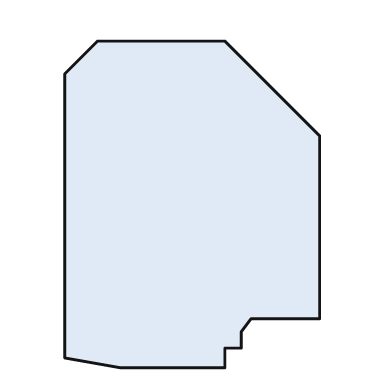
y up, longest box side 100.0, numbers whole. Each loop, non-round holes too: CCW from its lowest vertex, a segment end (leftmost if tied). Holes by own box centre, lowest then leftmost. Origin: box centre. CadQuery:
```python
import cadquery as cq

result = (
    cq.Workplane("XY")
    .moveTo(-22.0, -50.0)
    .lineTo(10.0, -50.0)
    .lineTo(10.0, -44.0)
    .lineTo(15.0, -44.0)
    .lineTo(15.0, -39.0)
    .lineTo(18.0, -35.0)
    .lineTo(39.0, -35.0)
    .lineTo(39.0, 21.0)
    .lineTo(10.0, 50.0)
    .lineTo(-29.0, 50.0)
    .lineTo(-39.0, 40.0)
    .lineTo(-39.0, -47.0)
    .close()
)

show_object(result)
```